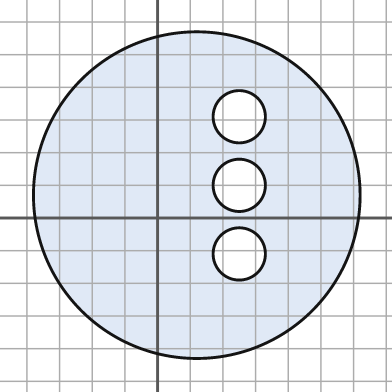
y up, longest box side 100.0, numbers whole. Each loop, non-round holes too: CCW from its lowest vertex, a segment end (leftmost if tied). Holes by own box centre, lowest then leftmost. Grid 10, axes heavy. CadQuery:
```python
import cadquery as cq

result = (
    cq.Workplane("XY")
    .moveTo(12.0, 7.0)
    .circle(50.0)
    .moveTo(25.0, -11.0)
    .circle(8.0)
    .moveTo(25.0, 10.0)
    .circle(8.0)
    .moveTo(25.0, 31.0)
    .circle(8.0)
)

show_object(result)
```